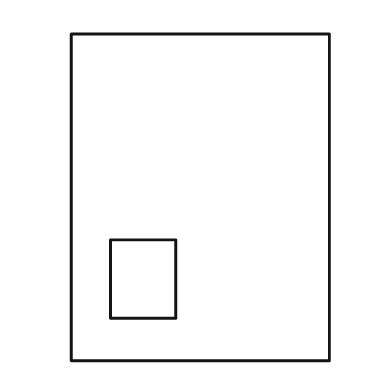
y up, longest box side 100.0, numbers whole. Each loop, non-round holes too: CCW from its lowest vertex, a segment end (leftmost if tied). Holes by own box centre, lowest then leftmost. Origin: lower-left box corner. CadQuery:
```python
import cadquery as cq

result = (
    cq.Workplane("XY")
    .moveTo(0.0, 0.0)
    .lineTo(79.0, 0.0)
    .lineTo(79.0, 100.0)
    .lineTo(0.0, 100.0)
    .close()
    .moveTo(12.0, 13.0)
    .lineTo(32.0, 13.0)
    .lineTo(32.0, 37.0)
    .lineTo(12.0, 37.0)
    .close()
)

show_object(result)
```